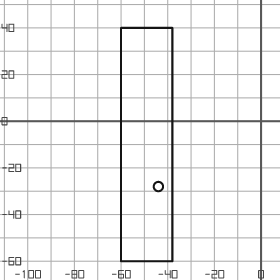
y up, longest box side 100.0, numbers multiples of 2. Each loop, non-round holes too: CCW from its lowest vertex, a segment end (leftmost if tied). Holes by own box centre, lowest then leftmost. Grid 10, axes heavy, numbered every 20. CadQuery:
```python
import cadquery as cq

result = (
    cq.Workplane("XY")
    .moveTo(-60.0, -60.0)
    .lineTo(-38.0, -60.0)
    .lineTo(-38.0, 40.0)
    .lineTo(-60.0, 40.0)
    .close()
    .moveTo(-44.0, -28.0)
    .circle(2.0)
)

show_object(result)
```